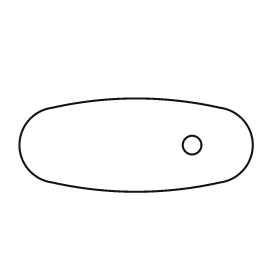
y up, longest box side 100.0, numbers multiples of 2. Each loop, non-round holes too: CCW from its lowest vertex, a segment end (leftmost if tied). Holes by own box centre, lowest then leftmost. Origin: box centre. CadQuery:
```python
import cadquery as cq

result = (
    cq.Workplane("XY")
    .moveTo(-36.0, -16.0)
    .threePointArc((0.0, -20.0), (36.0, -16.0))
    .threePointArc((50.0, 0.0), (36.0, 16.0))
    .threePointArc((0.0, 20.0), (-36.0, 16.0))
    .threePointArc((-50.0, 0.0), (-36.0, -16.0))
    .close()
    .moveTo(24.0, 0.0)
    .circle(4.0)
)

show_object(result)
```